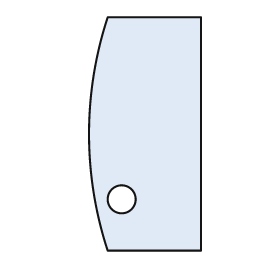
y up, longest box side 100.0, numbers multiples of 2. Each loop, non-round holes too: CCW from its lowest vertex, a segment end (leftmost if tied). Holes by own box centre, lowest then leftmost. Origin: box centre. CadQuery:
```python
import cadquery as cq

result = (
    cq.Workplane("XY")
    .moveTo(-16.0, -50.0)
    .lineTo(24.0, -50.0)
    .lineTo(24.0, 50.0)
    .lineTo(-16.0, 50.0)
    .threePointArc((-24.0, 0.0), (-16.0, -50.0))
    .close()
    .moveTo(-10.0, -28.0)
    .circle(6.0)
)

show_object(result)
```